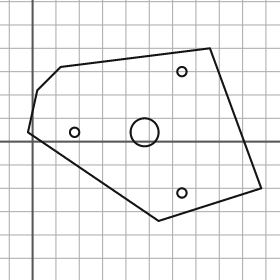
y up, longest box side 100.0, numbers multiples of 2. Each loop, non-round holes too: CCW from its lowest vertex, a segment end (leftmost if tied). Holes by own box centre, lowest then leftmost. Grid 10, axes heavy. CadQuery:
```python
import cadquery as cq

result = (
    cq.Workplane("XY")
    .moveTo(54.0, -34.0)
    .lineTo(98.0, -20.0)
    .lineTo(76.0, 40.0)
    .lineTo(12.0, 32.0)
    .lineTo(2.0, 22.0)
    .lineTo(-2.0, 4.0)
    .close()
    .moveTo(64.0, -22.0)
    .circle(2.0)
    .moveTo(18.0, 4.0)
    .circle(2.0)
    .moveTo(48.0, 4.0)
    .circle(6.0)
    .moveTo(64.0, 30.0)
    .circle(2.0)
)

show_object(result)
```